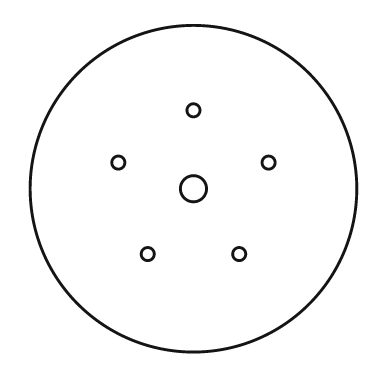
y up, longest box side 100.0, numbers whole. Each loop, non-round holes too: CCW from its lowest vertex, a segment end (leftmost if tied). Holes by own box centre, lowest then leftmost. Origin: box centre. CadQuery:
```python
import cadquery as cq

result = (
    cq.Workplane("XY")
    .moveTo(0.0, 0.0)
    .circle(50.0)
    .moveTo(-14.0, -20.0)
    .circle(2.0)
    .moveTo(14.0, -20.0)
    .circle(2.0)
    .moveTo(0.0, 0.0)
    .circle(4.0)
    .moveTo(-23.0, 8.0)
    .circle(2.0)
    .moveTo(23.0, 8.0)
    .circle(2.0)
    .moveTo(0.0, 24.0)
    .circle(2.0)
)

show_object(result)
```